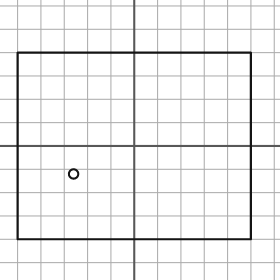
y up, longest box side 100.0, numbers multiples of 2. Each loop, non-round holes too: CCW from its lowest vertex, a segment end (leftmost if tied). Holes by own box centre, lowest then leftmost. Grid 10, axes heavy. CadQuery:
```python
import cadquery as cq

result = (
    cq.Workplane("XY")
    .moveTo(-50.0, -40.0)
    .lineTo(50.0, -40.0)
    .lineTo(50.0, 40.0)
    .lineTo(-50.0, 40.0)
    .close()
    .moveTo(-26.0, -12.0)
    .circle(2.0)
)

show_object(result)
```